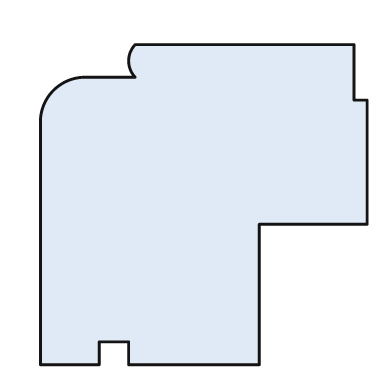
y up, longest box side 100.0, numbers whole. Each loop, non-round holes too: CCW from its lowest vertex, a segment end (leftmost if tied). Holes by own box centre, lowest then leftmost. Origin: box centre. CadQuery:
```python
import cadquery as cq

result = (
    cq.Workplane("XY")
    .moveTo(-50.0, -49.0)
    .lineTo(-32.0, -49.0)
    .lineTo(-32.0, -42.0)
    .lineTo(-23.0, -42.0)
    .lineTo(-23.0, -49.0)
    .lineTo(17.0, -49.0)
    .lineTo(17.0, -6.0)
    .lineTo(50.0, -6.0)
    .lineTo(50.0, 32.0)
    .lineTo(46.0, 32.0)
    .lineTo(46.0, 49.0)
    .lineTo(-21.0, 49.0)
    .threePointArc((-23.0, 44.0), (-21.0, 39.0))
    .lineTo(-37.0, 39.0)
    .threePointArc((-46.0, 35.0), (-50.0, 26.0))
    .close()
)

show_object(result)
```